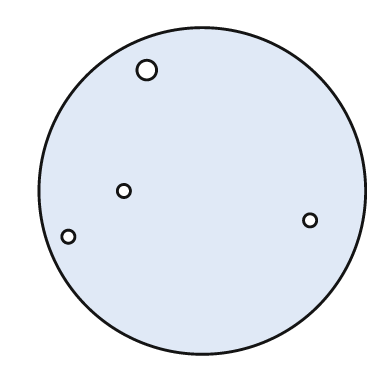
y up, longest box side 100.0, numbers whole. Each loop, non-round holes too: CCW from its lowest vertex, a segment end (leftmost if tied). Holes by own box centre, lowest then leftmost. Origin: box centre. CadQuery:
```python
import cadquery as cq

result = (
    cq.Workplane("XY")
    .moveTo(0.0, 0.0)
    .circle(50.0)
    .moveTo(-41.0, -14.0)
    .circle(2.0)
    .moveTo(33.0, -9.0)
    .circle(2.0)
    .moveTo(-24.0, 0.0)
    .circle(2.0)
    .moveTo(-17.0, 37.0)
    .circle(3.0)
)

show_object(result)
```